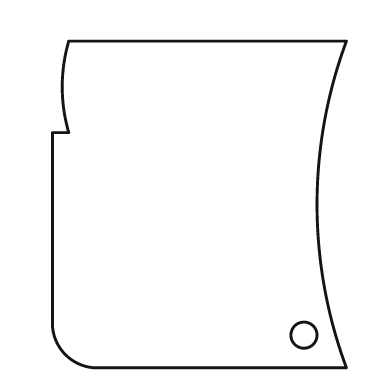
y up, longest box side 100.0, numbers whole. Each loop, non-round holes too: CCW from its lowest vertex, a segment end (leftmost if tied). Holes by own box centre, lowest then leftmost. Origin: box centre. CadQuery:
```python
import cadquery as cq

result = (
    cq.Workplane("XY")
    .moveTo(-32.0, -50.0)
    .lineTo(45.0, -50.0)
    .threePointArc((36.0, 0.0), (45.0, 50.0))
    .lineTo(-40.0, 50.0)
    .threePointArc((-42.0, 36.0), (-40.0, 22.0))
    .lineTo(-45.0, 22.0)
    .lineTo(-45.0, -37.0)
    .threePointArc((-41.0, -46.0), (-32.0, -50.0))
    .close()
    .moveTo(32.0, -40.0)
    .circle(4.0)
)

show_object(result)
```